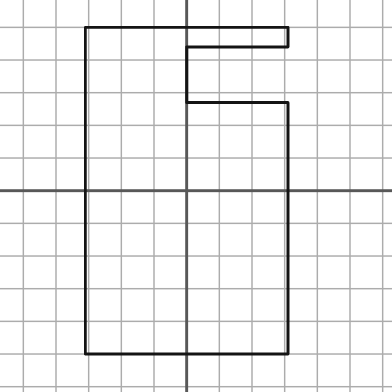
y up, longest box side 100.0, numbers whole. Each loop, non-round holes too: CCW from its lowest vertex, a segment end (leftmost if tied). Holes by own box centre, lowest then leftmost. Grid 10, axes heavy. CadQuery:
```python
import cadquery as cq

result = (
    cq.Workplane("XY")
    .moveTo(-31.0, -50.0)
    .lineTo(31.0, -50.0)
    .lineTo(31.0, 27.0)
    .lineTo(0.0, 27.0)
    .lineTo(0.0, 44.0)
    .lineTo(31.0, 44.0)
    .lineTo(31.0, 50.0)
    .lineTo(-31.0, 50.0)
    .close()
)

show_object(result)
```